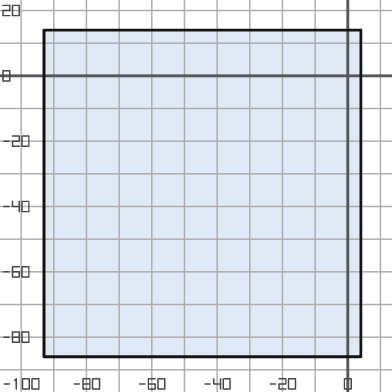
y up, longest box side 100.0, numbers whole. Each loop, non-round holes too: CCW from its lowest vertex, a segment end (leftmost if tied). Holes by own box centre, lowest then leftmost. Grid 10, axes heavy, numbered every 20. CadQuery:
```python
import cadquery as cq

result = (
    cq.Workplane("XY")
    .moveTo(-93.0, -86.0)
    .lineTo(4.0, -86.0)
    .lineTo(4.0, 14.0)
    .lineTo(-93.0, 14.0)
    .close()
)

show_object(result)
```